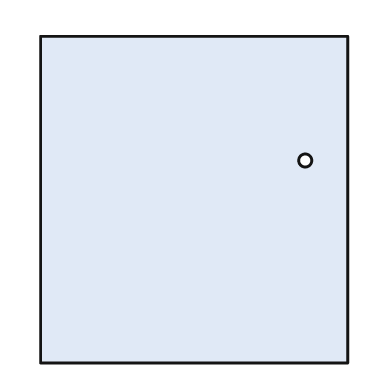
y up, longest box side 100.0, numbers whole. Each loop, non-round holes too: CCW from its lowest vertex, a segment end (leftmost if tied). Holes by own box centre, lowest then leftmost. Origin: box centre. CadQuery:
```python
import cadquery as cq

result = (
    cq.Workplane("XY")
    .moveTo(-47.0, -50.0)
    .lineTo(47.0, -50.0)
    .lineTo(47.0, 50.0)
    .lineTo(-47.0, 50.0)
    .close()
    .moveTo(34.0, 12.0)
    .circle(2.0)
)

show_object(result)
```